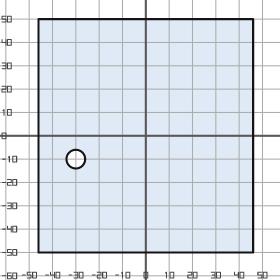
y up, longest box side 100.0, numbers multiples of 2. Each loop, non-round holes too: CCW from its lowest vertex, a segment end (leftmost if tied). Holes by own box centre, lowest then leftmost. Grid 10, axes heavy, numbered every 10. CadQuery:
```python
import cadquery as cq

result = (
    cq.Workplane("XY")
    .moveTo(-46.0, -50.0)
    .lineTo(46.0, -50.0)
    .lineTo(46.0, 50.0)
    .lineTo(-46.0, 50.0)
    .close()
    .moveTo(-30.0, -10.0)
    .circle(4.0)
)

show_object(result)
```